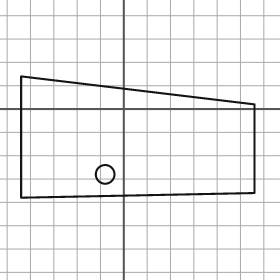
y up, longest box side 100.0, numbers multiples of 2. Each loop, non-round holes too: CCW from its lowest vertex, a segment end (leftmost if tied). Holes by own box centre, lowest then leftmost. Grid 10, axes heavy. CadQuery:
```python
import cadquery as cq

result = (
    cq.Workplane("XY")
    .moveTo(-44.0, -38.0)
    .lineTo(56.0, -36.0)
    .lineTo(56.0, 2.0)
    .lineTo(-44.0, 14.0)
    .close()
    .moveTo(-8.0, -28.0)
    .circle(4.0)
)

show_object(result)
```